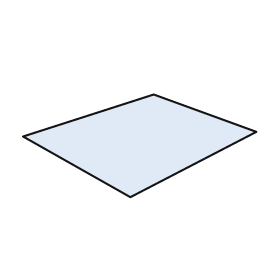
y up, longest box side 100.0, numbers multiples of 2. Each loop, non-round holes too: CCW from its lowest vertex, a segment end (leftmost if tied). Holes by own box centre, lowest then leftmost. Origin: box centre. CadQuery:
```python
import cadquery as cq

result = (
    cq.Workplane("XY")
    .moveTo(-4.0, -22.0)
    .lineTo(50.0, 6.0)
    .lineTo(6.0, 22.0)
    .lineTo(-50.0, 4.0)
    .close()
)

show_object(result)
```